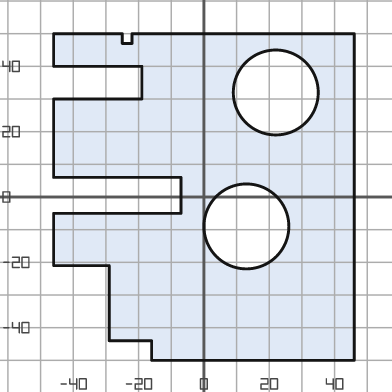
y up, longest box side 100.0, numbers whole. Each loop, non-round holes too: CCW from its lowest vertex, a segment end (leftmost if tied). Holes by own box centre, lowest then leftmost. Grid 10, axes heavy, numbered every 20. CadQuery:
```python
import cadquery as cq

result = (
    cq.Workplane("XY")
    .moveTo(-16.0, -50.0)
    .lineTo(46.0, -50.0)
    .lineTo(46.0, 50.0)
    .lineTo(-22.0, 50.0)
    .lineTo(-22.0, 47.0)
    .lineTo(-25.0, 47.0)
    .lineTo(-25.0, 50.0)
    .lineTo(-46.0, 50.0)
    .lineTo(-46.0, 40.0)
    .lineTo(-19.0, 40.0)
    .lineTo(-19.0, 30.0)
    .lineTo(-46.0, 30.0)
    .lineTo(-46.0, 6.0)
    .lineTo(-7.0, 6.0)
    .lineTo(-7.0, -5.0)
    .lineTo(-46.0, -5.0)
    .lineTo(-46.0, -21.0)
    .lineTo(-29.0, -21.0)
    .lineTo(-29.0, -44.0)
    .lineTo(-16.0, -44.0)
    .close()
    .moveTo(13.0, -9.0)
    .circle(13.0)
    .moveTo(22.0, 32.0)
    .circle(13.0)
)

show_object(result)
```